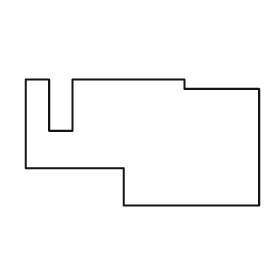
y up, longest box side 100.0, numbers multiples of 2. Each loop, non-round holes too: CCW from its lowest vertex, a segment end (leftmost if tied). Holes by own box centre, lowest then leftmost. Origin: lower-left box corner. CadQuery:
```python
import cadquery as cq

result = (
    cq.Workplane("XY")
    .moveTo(42.0, 0.0)
    .lineTo(100.0, 0.0)
    .lineTo(100.0, 50.0)
    .lineTo(68.0, 50.0)
    .lineTo(68.0, 54.0)
    .lineTo(20.0, 54.0)
    .lineTo(20.0, 32.0)
    .lineTo(10.0, 32.0)
    .lineTo(10.0, 54.0)
    .lineTo(0.0, 54.0)
    .lineTo(0.0, 16.0)
    .lineTo(42.0, 16.0)
    .close()
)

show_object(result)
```